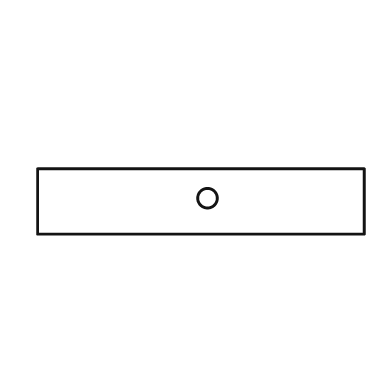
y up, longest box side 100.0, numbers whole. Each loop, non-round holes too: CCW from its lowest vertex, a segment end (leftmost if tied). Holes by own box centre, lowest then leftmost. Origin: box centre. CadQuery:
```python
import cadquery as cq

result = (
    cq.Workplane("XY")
    .moveTo(-50.0, -10.0)
    .lineTo(50.0, -10.0)
    .lineTo(50.0, 10.0)
    .lineTo(-50.0, 10.0)
    .close()
    .moveTo(2.0, 1.0)
    .circle(3.0)
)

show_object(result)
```